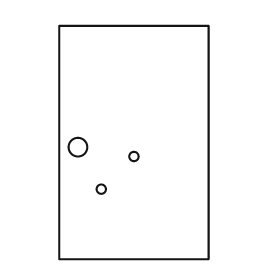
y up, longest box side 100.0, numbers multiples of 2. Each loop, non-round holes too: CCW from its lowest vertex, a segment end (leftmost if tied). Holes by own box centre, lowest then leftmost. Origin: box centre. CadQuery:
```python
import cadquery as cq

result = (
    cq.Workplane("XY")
    .moveTo(-32.0, -50.0)
    .lineTo(32.0, -50.0)
    .lineTo(32.0, 50.0)
    .lineTo(-32.0, 50.0)
    .close()
    .moveTo(-14.0, -20.0)
    .circle(2.0)
    .moveTo(0.0, -6.0)
    .circle(2.0)
    .moveTo(-24.0, -2.0)
    .circle(4.0)
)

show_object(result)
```